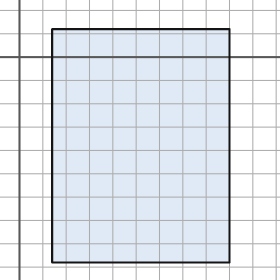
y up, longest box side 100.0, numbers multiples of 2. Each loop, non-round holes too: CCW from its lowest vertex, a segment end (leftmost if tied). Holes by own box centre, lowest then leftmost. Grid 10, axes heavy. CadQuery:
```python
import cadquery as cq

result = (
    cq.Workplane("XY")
    .moveTo(14.0, -88.0)
    .lineTo(90.0, -88.0)
    .lineTo(90.0, 12.0)
    .lineTo(14.0, 12.0)
    .close()
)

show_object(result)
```